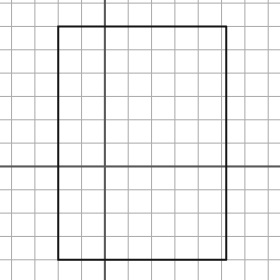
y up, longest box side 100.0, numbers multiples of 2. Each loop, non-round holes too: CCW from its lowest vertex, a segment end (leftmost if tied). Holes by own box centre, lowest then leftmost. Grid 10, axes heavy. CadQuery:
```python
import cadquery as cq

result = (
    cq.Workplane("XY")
    .moveTo(-20.0, -40.0)
    .lineTo(52.0, -40.0)
    .lineTo(52.0, 60.0)
    .lineTo(-20.0, 60.0)
    .close()
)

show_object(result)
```